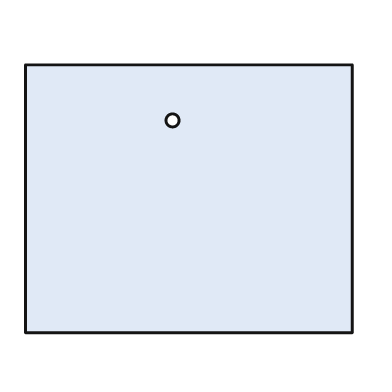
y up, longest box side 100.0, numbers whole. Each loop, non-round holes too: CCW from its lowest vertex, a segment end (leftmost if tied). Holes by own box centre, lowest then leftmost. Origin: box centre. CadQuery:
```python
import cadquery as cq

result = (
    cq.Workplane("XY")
    .moveTo(-50.0, -41.0)
    .lineTo(50.0, -41.0)
    .lineTo(50.0, 41.0)
    .lineTo(-50.0, 41.0)
    .close()
    .moveTo(-5.0, 24.0)
    .circle(2.0)
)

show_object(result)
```